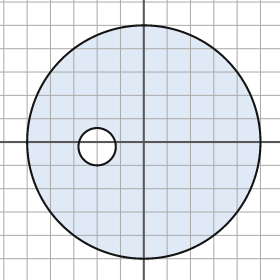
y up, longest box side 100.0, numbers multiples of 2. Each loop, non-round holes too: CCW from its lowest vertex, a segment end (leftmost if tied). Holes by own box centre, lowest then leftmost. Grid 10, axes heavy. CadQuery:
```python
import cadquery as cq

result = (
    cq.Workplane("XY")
    .moveTo(0.0, 0.0)
    .circle(50.0)
    .moveTo(-20.0, -2.0)
    .circle(8.0)
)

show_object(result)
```